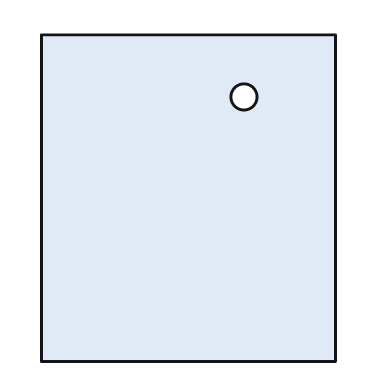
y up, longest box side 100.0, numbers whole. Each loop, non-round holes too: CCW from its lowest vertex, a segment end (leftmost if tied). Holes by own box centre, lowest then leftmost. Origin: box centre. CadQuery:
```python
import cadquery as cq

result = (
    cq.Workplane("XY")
    .moveTo(-45.0, -50.0)
    .lineTo(45.0, -50.0)
    .lineTo(45.0, 50.0)
    .lineTo(-45.0, 50.0)
    .close()
    .moveTo(17.0, 31.0)
    .circle(4.0)
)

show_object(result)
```